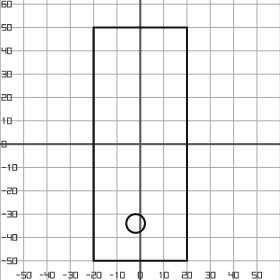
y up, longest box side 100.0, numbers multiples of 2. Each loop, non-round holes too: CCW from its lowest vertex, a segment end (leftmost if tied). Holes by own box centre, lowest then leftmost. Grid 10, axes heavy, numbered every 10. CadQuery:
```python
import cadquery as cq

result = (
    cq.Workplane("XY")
    .moveTo(-20.0, -50.0)
    .lineTo(20.0, -50.0)
    .lineTo(20.0, 50.0)
    .lineTo(-20.0, 50.0)
    .close()
    .moveTo(-2.0, -34.0)
    .circle(4.0)
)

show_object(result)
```